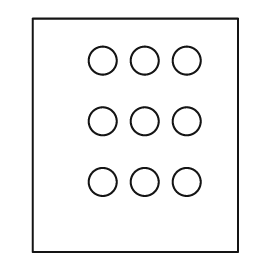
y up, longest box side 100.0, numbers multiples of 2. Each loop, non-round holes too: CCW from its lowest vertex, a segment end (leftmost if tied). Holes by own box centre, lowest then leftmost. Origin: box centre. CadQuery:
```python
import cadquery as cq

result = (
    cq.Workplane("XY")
    .moveTo(-44.0, -50.0)
    .lineTo(44.0, -50.0)
    .lineTo(44.0, 50.0)
    .lineTo(-44.0, 50.0)
    .close()
    .moveTo(-14.0, -20.0)
    .circle(6.0)
    .moveTo(4.0, -20.0)
    .circle(6.0)
    .moveTo(22.0, -20.0)
    .circle(6.0)
    .moveTo(-14.0, 6.0)
    .circle(6.0)
    .moveTo(4.0, 6.0)
    .circle(6.0)
    .moveTo(22.0, 6.0)
    .circle(6.0)
    .moveTo(-14.0, 32.0)
    .circle(6.0)
    .moveTo(4.0, 32.0)
    .circle(6.0)
    .moveTo(22.0, 32.0)
    .circle(6.0)
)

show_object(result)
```